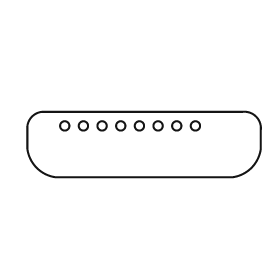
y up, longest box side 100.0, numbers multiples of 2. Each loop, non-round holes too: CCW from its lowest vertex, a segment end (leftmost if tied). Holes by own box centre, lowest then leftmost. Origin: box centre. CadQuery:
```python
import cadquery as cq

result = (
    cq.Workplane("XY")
    .moveTo(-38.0, -14.0)
    .lineTo(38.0, -14.0)
    .threePointArc((46.0, -10.0), (50.0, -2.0))
    .lineTo(50.0, 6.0)
    .threePointArc((48.0, 12.0), (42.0, 14.0))
    .lineTo(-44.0, 14.0)
    .threePointArc((-48.0, 12.0), (-50.0, 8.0))
    .lineTo(-50.0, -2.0)
    .threePointArc((-46.0, -10.0), (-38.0, -14.0))
    .close()
    .moveTo(-34.0, 8.0)
    .circle(2.0)
    .moveTo(-26.0, 8.0)
    .circle(2.0)
    .moveTo(-18.0, 8.0)
    .circle(2.0)
    .moveTo(-10.0, 8.0)
    .circle(2.0)
    .moveTo(-2.0, 8.0)
    .circle(2.0)
    .moveTo(6.0, 8.0)
    .circle(2.0)
    .moveTo(14.0, 8.0)
    .circle(2.0)
    .moveTo(22.0, 8.0)
    .circle(2.0)
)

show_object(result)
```